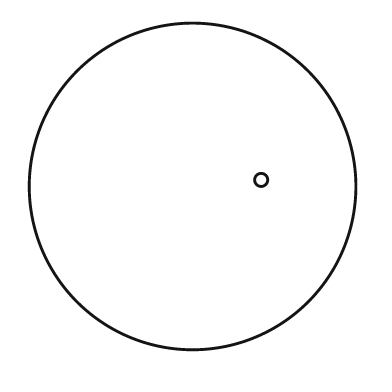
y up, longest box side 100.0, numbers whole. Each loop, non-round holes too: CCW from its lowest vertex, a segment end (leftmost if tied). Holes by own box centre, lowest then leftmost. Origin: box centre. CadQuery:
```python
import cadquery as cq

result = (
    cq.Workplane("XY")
    .moveTo(0.0, 0.0)
    .circle(50.0)
    .moveTo(21.0, 2.0)
    .circle(2.0)
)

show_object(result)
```